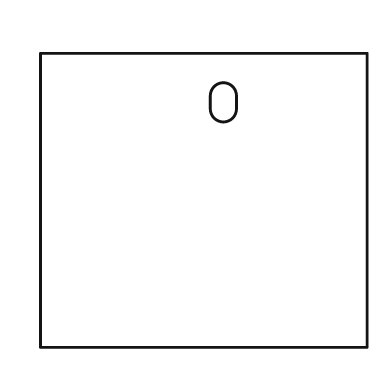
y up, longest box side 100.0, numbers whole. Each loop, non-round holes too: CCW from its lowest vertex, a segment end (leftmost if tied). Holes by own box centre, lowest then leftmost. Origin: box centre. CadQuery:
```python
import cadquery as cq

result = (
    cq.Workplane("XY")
    .moveTo(-50.0, -45.0)
    .lineTo(50.0, -45.0)
    .lineTo(50.0, 45.0)
    .lineTo(-50.0, 45.0)
    .close()
    .moveTo(2.0, 28.0)
    .threePointArc((6.0, 24.0), (10.0, 28.0))
    .lineTo(10.0, 32.0)
    .threePointArc((6.0, 36.0), (2.0, 32.0))
    .close()
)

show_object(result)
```